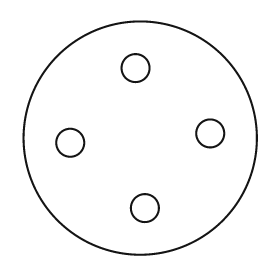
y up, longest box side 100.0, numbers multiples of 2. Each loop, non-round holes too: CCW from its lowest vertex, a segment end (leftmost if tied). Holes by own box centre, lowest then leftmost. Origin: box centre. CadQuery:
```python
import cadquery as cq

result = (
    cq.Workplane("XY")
    .moveTo(0.0, 0.0)
    .circle(50.0)
    .moveTo(2.0, -30.0)
    .circle(6.0)
    .moveTo(-30.0, -2.0)
    .circle(6.0)
    .moveTo(30.0, 2.0)
    .circle(6.0)
    .moveTo(-2.0, 30.0)
    .circle(6.0)
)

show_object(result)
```